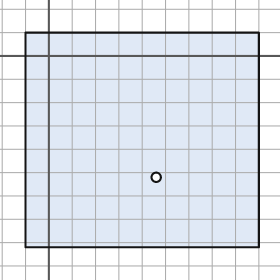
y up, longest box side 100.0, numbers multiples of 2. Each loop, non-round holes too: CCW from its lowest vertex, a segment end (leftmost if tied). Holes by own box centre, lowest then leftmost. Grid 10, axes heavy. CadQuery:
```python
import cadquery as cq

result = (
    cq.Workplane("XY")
    .moveTo(-10.0, -82.0)
    .lineTo(90.0, -82.0)
    .lineTo(90.0, 10.0)
    .lineTo(-10.0, 10.0)
    .close()
    .moveTo(46.0, -52.0)
    .circle(2.0)
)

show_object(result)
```